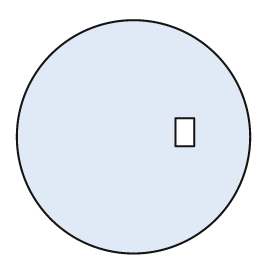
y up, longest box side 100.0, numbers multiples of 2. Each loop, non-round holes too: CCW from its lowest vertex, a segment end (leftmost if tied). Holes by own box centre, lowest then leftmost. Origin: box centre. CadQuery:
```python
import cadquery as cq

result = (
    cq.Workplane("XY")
    .moveTo(0.0, 0.0)
    .circle(50.0)
    .moveTo(18.0, -4.0)
    .lineTo(26.0, -4.0)
    .lineTo(26.0, 8.0)
    .lineTo(18.0, 8.0)
    .close()
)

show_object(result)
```